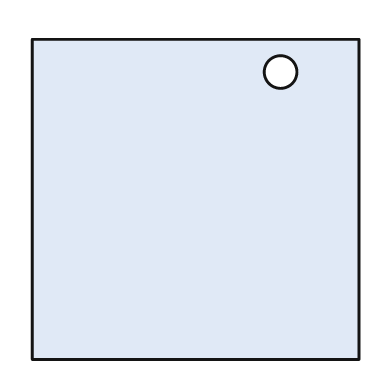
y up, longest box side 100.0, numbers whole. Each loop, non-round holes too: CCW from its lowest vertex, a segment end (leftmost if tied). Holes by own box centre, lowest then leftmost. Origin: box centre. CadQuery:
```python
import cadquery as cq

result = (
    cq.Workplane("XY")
    .moveTo(-50.0, -49.0)
    .lineTo(50.0, -49.0)
    .lineTo(50.0, 49.0)
    .lineTo(-50.0, 49.0)
    .close()
    .moveTo(26.0, 39.0)
    .circle(5.0)
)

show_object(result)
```